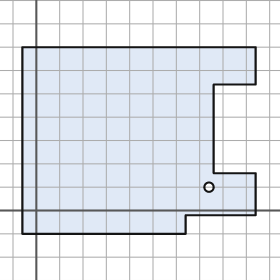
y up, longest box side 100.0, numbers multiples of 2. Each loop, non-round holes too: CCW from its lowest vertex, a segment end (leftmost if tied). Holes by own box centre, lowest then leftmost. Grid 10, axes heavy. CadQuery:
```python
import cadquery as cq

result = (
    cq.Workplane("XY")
    .moveTo(-6.0, -10.0)
    .lineTo(64.0, -10.0)
    .lineTo(64.0, -2.0)
    .lineTo(94.0, -2.0)
    .lineTo(94.0, 16.0)
    .lineTo(76.0, 16.0)
    .lineTo(76.0, 54.0)
    .lineTo(94.0, 54.0)
    .lineTo(94.0, 70.0)
    .lineTo(-6.0, 70.0)
    .close()
    .moveTo(74.0, 10.0)
    .circle(2.0)
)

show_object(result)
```